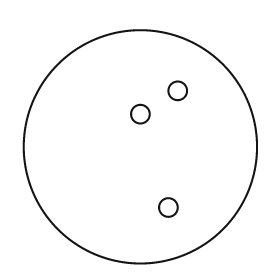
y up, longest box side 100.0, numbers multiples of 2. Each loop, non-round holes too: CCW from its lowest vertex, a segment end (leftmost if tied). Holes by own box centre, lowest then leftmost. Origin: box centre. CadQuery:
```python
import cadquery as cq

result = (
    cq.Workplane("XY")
    .moveTo(0.0, 0.0)
    .circle(50.0)
    .moveTo(12.0, -26.0)
    .circle(4.0)
    .moveTo(0.0, 14.0)
    .circle(4.0)
    .moveTo(16.0, 24.0)
    .circle(4.0)
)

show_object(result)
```